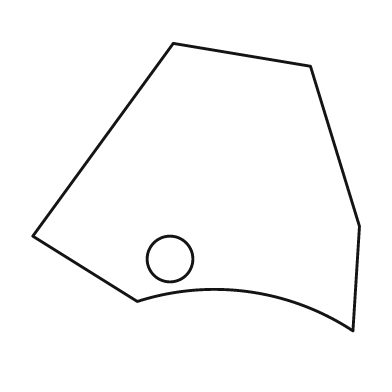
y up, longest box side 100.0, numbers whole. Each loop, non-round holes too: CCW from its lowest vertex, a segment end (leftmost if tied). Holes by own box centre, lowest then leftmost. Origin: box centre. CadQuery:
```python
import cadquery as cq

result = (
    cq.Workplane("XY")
    .moveTo(48.0, -44.0)
    .lineTo(50.0, -12.0)
    .lineTo(35.0, 37.0)
    .lineTo(-7.0, 44.0)
    .lineTo(-50.0, -15.0)
    .lineTo(-18.0, -35.0)
    .threePointArc((16.0, -32.0), (48.0, -44.0))
    .close()
    .moveTo(-8.0, -22.0)
    .circle(7.0)
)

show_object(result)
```